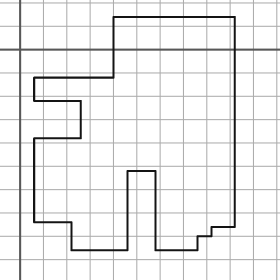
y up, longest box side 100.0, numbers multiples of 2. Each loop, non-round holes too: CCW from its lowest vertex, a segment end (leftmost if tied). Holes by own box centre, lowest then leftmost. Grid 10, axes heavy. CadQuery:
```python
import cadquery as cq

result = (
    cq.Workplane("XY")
    .moveTo(22.0, -86.0)
    .lineTo(46.0, -86.0)
    .lineTo(46.0, -52.0)
    .lineTo(58.0, -52.0)
    .lineTo(58.0, -86.0)
    .lineTo(76.0, -86.0)
    .lineTo(76.0, -80.0)
    .lineTo(82.0, -80.0)
    .lineTo(82.0, -76.0)
    .lineTo(92.0, -76.0)
    .lineTo(92.0, 14.0)
    .lineTo(40.0, 14.0)
    .lineTo(40.0, -12.0)
    .lineTo(6.0, -12.0)
    .lineTo(6.0, -22.0)
    .lineTo(26.0, -22.0)
    .lineTo(26.0, -38.0)
    .lineTo(6.0, -38.0)
    .lineTo(6.0, -74.0)
    .lineTo(22.0, -74.0)
    .close()
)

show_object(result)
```